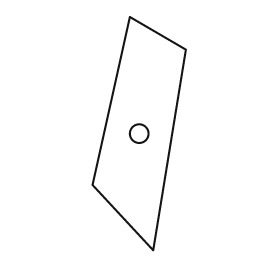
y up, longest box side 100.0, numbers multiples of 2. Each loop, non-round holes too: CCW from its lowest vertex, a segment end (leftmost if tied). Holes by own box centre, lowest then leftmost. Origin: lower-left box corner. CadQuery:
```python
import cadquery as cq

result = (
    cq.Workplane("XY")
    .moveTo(26.0, 0.0)
    .lineTo(40.0, 86.0)
    .lineTo(16.0, 100.0)
    .lineTo(0.0, 28.0)
    .close()
    .moveTo(20.0, 50.0)
    .circle(4.0)
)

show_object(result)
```